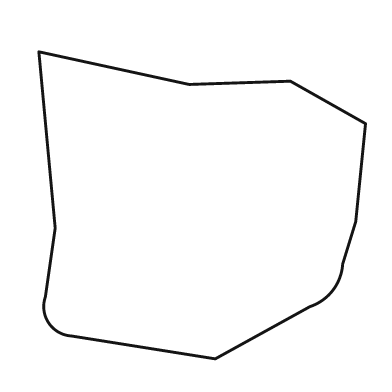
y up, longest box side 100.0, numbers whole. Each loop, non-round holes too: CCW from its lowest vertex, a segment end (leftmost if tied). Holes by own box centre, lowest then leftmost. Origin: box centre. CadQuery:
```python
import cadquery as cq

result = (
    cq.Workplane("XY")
    .moveTo(4.0, -47.0)
    .lineTo(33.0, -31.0)
    .threePointArc((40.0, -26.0), (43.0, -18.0))
    .lineTo(47.0, -5.0)
    .lineTo(50.0, 25.0)
    .lineTo(27.0, 38.0)
    .lineTo(-4.0, 37.0)
    .lineTo(-50.0, 47.0)
    .lineTo(-45.0, -7.0)
    .lineTo(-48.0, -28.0)
    .threePointArc((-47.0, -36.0), (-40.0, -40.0))
    .close()
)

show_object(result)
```